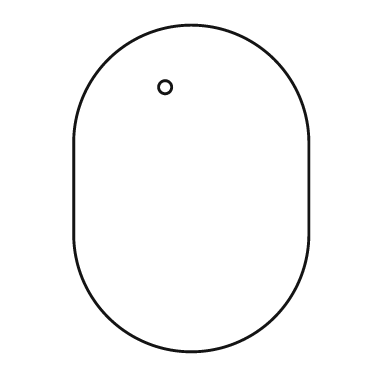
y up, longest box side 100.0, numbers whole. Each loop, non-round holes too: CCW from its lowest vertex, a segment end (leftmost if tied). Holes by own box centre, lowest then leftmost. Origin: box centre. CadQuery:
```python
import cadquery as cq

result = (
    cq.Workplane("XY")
    .moveTo(-36.0, -14.0)
    .threePointArc((0.0, -50.0), (36.0, -14.0))
    .lineTo(36.0, 14.0)
    .threePointArc((0.0, 50.0), (-36.0, 14.0))
    .close()
    .moveTo(-8.0, 31.0)
    .circle(2.0)
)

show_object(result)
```